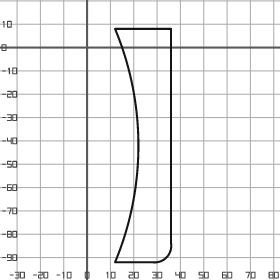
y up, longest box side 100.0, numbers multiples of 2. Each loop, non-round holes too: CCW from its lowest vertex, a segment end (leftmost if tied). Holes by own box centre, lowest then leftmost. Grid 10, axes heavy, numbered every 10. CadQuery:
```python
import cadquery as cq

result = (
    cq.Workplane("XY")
    .moveTo(12.0, -92.0)
    .lineTo(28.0, -92.0)
    .threePointArc((34.0, -90.0), (36.0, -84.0))
    .lineTo(36.0, 8.0)
    .lineTo(12.0, 8.0)
    .threePointArc((22.0, -42.0), (12.0, -92.0))
    .close()
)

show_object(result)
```